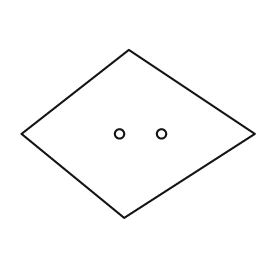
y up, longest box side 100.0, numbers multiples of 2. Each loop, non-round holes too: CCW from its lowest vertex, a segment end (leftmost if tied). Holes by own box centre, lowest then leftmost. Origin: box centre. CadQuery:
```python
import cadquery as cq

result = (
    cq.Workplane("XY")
    .moveTo(-6.0, -36.0)
    .lineTo(50.0, 0.0)
    .lineTo(-4.0, 36.0)
    .lineTo(-50.0, 0.0)
    .close()
    .moveTo(-8.0, 0.0)
    .circle(2.0)
    .moveTo(10.0, 0.0)
    .circle(2.0)
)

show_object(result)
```